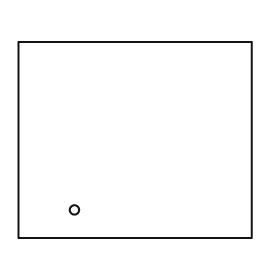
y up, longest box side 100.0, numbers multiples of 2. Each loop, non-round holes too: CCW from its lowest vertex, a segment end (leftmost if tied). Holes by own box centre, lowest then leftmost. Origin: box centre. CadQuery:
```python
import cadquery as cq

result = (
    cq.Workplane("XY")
    .moveTo(-50.0, -42.0)
    .lineTo(50.0, -42.0)
    .lineTo(50.0, 42.0)
    .lineTo(-50.0, 42.0)
    .close()
    .moveTo(-26.0, -30.0)
    .circle(2.0)
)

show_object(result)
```